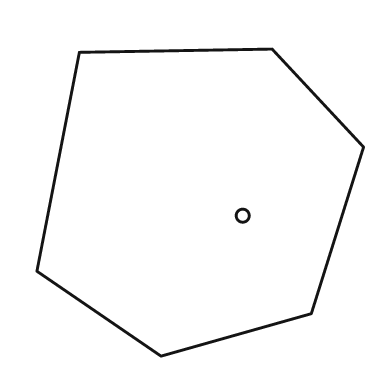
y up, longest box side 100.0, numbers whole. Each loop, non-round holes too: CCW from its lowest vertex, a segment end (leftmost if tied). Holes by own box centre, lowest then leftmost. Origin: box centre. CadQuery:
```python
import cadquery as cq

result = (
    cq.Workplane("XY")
    .moveTo(-12.0, -47.0)
    .lineTo(34.0, -34.0)
    .lineTo(50.0, 17.0)
    .lineTo(22.0, 47.0)
    .lineTo(-37.0, 46.0)
    .lineTo(-50.0, -21.0)
    .close()
    .moveTo(13.0, -4.0)
    .circle(2.0)
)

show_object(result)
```